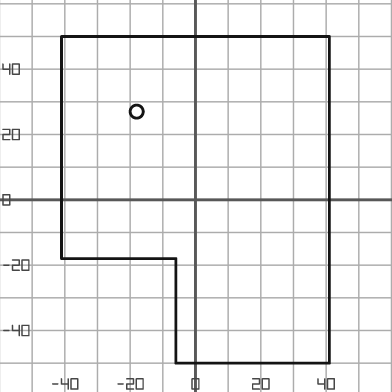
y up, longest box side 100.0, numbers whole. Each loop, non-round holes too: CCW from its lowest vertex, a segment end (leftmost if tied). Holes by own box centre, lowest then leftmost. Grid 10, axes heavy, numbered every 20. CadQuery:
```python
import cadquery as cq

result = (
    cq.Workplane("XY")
    .moveTo(-6.0, -50.0)
    .lineTo(41.0, -50.0)
    .lineTo(41.0, 50.0)
    .lineTo(-41.0, 50.0)
    .lineTo(-41.0, -18.0)
    .lineTo(-6.0, -18.0)
    .close()
    .moveTo(-18.0, 27.0)
    .circle(2.0)
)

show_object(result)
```